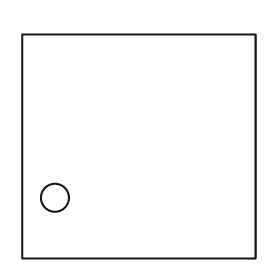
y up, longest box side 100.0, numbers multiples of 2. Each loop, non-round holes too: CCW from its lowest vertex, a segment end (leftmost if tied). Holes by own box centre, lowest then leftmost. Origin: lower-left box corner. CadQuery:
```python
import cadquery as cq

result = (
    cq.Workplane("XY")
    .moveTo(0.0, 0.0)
    .lineTo(100.0, 0.0)
    .lineTo(100.0, 96.0)
    .lineTo(0.0, 96.0)
    .close()
    .moveTo(14.0, 26.0)
    .circle(6.0)
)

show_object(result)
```